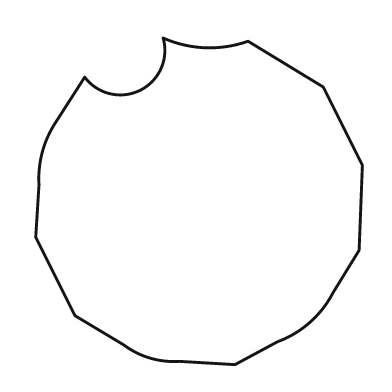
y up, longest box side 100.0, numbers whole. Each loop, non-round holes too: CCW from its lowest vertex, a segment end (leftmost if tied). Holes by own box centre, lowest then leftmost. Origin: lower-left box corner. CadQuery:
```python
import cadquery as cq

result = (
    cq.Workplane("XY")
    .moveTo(61.0, 0.0)
    .lineTo(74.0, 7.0)
    .threePointArc((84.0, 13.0), (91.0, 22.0))
    .lineTo(99.0, 35.0)
    .lineTo(100.0, 61.0)
    .lineTo(88.0, 85.0)
    .lineTo(65.0, 99.0)
    .threePointArc((52.0, 97.0), (39.0, 100.0))
    .threePointArc((32.0, 84.0), (15.0, 88.0))
    .lineTo(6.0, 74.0)
    .threePointArc((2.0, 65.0), (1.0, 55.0))
    .lineTo(0.0, 39.0)
    .lineTo(12.0, 15.0)
    .lineTo(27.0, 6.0)
    .threePointArc((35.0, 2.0), (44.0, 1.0))
    .close()
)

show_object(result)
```